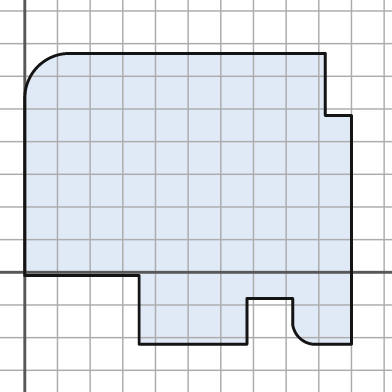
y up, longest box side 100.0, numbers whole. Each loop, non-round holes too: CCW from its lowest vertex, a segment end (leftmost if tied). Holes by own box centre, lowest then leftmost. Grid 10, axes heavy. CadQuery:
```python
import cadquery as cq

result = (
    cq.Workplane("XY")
    .moveTo(35.0, -22.0)
    .lineTo(68.0, -22.0)
    .lineTo(68.0, -8.0)
    .lineTo(82.0, -8.0)
    .lineTo(82.0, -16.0)
    .threePointArc((84.0, -20.0), (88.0, -22.0))
    .lineTo(100.0, -22.0)
    .lineTo(100.0, 48.0)
    .lineTo(92.0, 48.0)
    .lineTo(92.0, 67.0)
    .lineTo(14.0, 67.0)
    .threePointArc((4.0, 63.0), (0.0, 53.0))
    .lineTo(0.0, -1.0)
    .lineTo(35.0, -1.0)
    .close()
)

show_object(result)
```